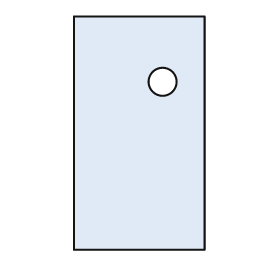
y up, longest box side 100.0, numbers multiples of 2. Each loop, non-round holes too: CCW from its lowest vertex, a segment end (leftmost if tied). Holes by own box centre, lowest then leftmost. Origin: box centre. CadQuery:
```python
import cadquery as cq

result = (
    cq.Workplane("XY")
    .moveTo(-28.0, -50.0)
    .lineTo(28.0, -50.0)
    .lineTo(28.0, 50.0)
    .lineTo(-28.0, 50.0)
    .close()
    .moveTo(10.0, 22.0)
    .circle(6.0)
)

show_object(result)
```